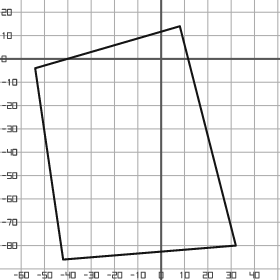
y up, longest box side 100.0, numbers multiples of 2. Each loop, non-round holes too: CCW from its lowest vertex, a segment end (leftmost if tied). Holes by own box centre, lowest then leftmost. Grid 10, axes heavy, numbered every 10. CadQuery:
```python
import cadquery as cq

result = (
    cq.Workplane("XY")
    .moveTo(-42.0, -86.0)
    .lineTo(32.0, -80.0)
    .lineTo(8.0, 14.0)
    .lineTo(-54.0, -4.0)
    .close()
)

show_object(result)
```